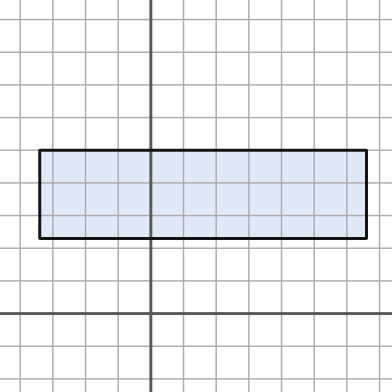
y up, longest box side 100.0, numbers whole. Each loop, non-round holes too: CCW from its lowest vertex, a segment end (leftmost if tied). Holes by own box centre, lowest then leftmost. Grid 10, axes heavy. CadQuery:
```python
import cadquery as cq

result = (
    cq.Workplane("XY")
    .moveTo(-34.0, 23.0)
    .lineTo(66.0, 23.0)
    .lineTo(66.0, 50.0)
    .lineTo(-34.0, 50.0)
    .close()
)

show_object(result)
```